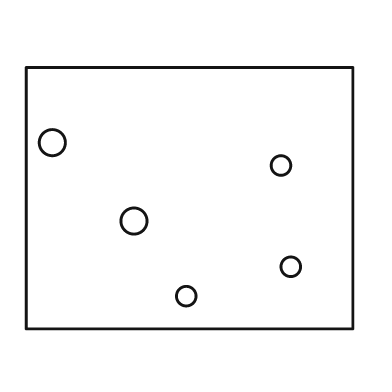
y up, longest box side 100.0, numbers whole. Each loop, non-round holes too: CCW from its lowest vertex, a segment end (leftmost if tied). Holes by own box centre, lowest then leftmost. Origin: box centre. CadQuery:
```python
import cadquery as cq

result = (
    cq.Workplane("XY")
    .moveTo(-50.0, -40.0)
    .lineTo(50.0, -40.0)
    .lineTo(50.0, 40.0)
    .lineTo(-50.0, 40.0)
    .close()
    .moveTo(-1.0, -30.0)
    .circle(3.0)
    .moveTo(31.0, -21.0)
    .circle(3.0)
    .moveTo(-17.0, -7.0)
    .circle(4.0)
    .moveTo(28.0, 10.0)
    .circle(3.0)
    .moveTo(-42.0, 17.0)
    .circle(4.0)
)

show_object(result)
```